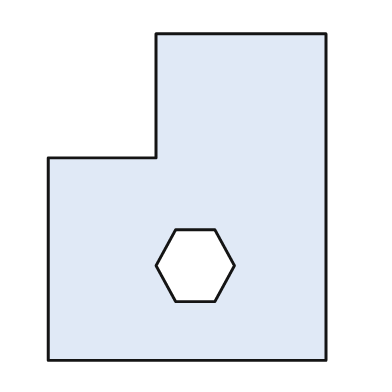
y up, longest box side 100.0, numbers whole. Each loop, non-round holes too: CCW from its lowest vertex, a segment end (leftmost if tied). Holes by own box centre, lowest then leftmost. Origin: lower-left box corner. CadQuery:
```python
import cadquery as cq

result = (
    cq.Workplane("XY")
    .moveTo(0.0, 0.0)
    .lineTo(85.0, 0.0)
    .lineTo(85.0, 100.0)
    .lineTo(33.0, 100.0)
    .lineTo(33.0, 62.0)
    .lineTo(0.0, 62.0)
    .close()
    .moveTo(39.0, 18.0)
    .lineTo(51.0, 18.0)
    .lineTo(57.0, 29.0)
    .lineTo(51.0, 40.0)
    .lineTo(39.0, 40.0)
    .lineTo(33.0, 29.0)
    .close()
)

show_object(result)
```